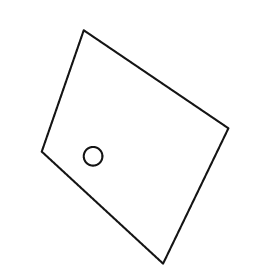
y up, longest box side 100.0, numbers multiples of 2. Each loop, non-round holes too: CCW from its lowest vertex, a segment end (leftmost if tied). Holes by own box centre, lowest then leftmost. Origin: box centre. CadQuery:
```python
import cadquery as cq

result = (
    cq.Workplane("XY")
    .moveTo(12.0, -50.0)
    .lineTo(40.0, 8.0)
    .lineTo(-22.0, 50.0)
    .lineTo(-40.0, -2.0)
    .close()
    .moveTo(-18.0, -4.0)
    .circle(4.0)
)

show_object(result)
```